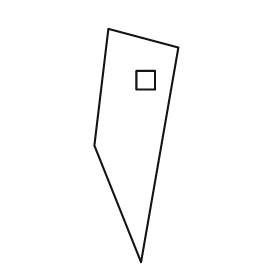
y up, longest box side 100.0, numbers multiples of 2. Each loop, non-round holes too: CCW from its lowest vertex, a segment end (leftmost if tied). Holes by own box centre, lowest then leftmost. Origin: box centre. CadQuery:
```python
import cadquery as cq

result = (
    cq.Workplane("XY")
    .moveTo(2.0, -50.0)
    .lineTo(18.0, 42.0)
    .lineTo(-12.0, 50.0)
    .lineTo(-18.0, 0.0)
    .close()
    .moveTo(0.0, 24.0)
    .lineTo(8.0, 24.0)
    .lineTo(8.0, 32.0)
    .lineTo(0.0, 32.0)
    .close()
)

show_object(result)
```